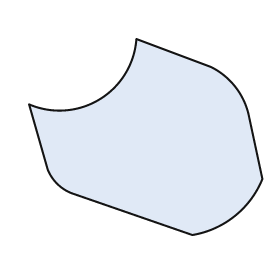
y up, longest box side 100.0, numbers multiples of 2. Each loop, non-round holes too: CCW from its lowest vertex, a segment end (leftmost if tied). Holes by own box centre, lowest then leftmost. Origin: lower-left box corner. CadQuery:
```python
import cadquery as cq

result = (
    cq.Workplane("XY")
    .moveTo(70.0, 0.0)
    .threePointArc((88.0, 8.0), (100.0, 24.0))
    .lineTo(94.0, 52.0)
    .threePointArc((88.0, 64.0), (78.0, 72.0))
    .lineTo(46.0, 84.0)
    .threePointArc((30.0, 58.0), (0.0, 56.0))
    .lineTo(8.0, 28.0)
    .threePointArc((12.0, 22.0), (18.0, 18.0))
    .close()
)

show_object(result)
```